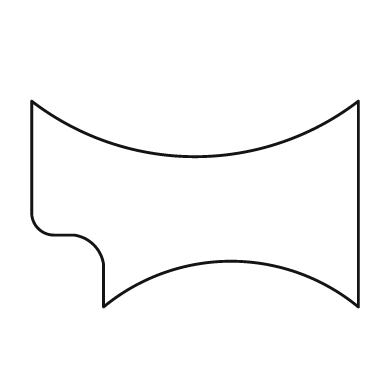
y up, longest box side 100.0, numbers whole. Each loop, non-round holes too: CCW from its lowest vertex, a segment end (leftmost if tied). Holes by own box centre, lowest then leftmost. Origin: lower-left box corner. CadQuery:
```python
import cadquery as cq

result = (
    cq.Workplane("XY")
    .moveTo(22.0, 0.0)
    .threePointArc((61.0, 14.0), (100.0, 0.0))
    .lineTo(100.0, 63.0)
    .threePointArc((50.0, 46.0), (0.0, 63.0))
    .lineTo(0.0, 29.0)
    .threePointArc((2.0, 24.0), (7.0, 22.0))
    .lineTo(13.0, 22.0)
    .threePointArc((19.0, 19.0), (22.0, 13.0))
    .close()
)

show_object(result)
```